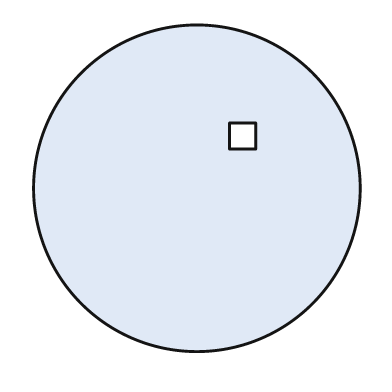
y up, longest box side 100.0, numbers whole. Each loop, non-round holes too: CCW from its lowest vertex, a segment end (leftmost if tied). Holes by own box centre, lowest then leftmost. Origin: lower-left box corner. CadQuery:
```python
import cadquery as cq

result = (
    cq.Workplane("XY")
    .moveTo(50.0, 50.0)
    .circle(50.0)
    .moveTo(60.0, 62.0)
    .lineTo(68.0, 62.0)
    .lineTo(68.0, 70.0)
    .lineTo(60.0, 70.0)
    .close()
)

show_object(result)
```